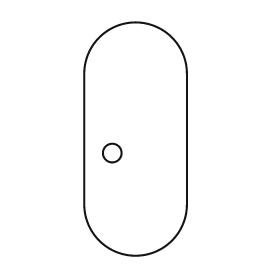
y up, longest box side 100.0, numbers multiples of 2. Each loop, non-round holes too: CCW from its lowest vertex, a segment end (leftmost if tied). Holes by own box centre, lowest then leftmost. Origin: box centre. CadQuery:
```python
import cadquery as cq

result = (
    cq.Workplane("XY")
    .moveTo(-22.0, -28.0)
    .threePointArc((0.0, -50.0), (22.0, -28.0))
    .lineTo(22.0, 28.0)
    .threePointArc((0.0, 50.0), (-22.0, 28.0))
    .close()
    .moveTo(-10.0, -6.0)
    .circle(4.0)
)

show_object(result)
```